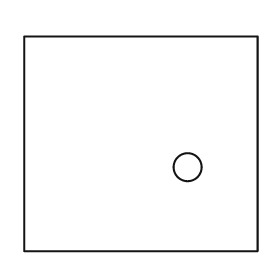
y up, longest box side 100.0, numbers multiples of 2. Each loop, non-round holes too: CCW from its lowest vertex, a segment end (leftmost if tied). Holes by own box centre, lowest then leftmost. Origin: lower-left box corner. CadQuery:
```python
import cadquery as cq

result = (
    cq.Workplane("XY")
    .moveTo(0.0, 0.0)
    .lineTo(100.0, 0.0)
    .lineTo(100.0, 92.0)
    .lineTo(0.0, 92.0)
    .close()
    .moveTo(70.0, 36.0)
    .circle(6.0)
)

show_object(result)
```